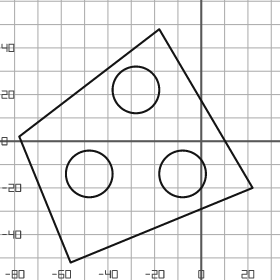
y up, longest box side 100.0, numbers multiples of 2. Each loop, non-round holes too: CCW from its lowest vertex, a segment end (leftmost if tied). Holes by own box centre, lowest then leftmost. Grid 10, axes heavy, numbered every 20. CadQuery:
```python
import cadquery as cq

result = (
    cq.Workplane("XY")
    .moveTo(-56.0, -52.0)
    .lineTo(22.0, -20.0)
    .lineTo(-18.0, 48.0)
    .lineTo(-78.0, 2.0)
    .close()
    .moveTo(-48.0, -14.0)
    .circle(10.0)
    .moveTo(-8.0, -14.0)
    .circle(10.0)
    .moveTo(-28.0, 22.0)
    .circle(10.0)
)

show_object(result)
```